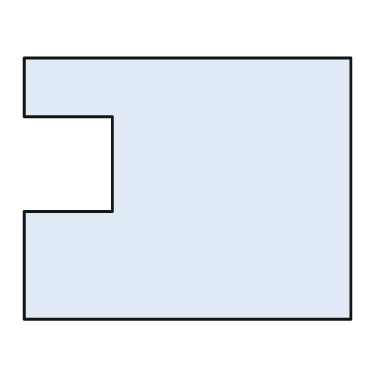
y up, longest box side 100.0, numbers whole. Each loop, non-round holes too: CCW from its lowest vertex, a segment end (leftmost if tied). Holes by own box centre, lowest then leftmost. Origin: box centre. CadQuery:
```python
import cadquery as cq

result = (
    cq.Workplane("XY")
    .moveTo(-50.0, -40.0)
    .lineTo(50.0, -40.0)
    .lineTo(50.0, 40.0)
    .lineTo(-50.0, 40.0)
    .lineTo(-50.0, 22.0)
    .lineTo(-23.0, 22.0)
    .lineTo(-23.0, -7.0)
    .lineTo(-50.0, -7.0)
    .close()
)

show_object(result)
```